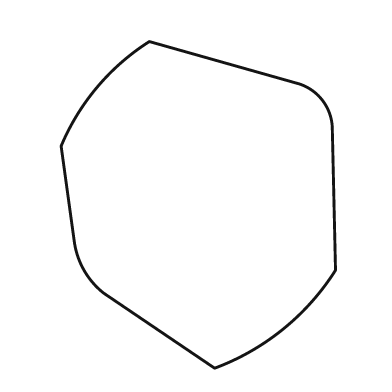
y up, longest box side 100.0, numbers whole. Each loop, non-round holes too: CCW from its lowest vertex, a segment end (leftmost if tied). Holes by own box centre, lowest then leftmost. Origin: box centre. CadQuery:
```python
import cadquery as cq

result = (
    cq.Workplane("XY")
    .moveTo(5.0, -50.0)
    .threePointArc((26.0, -38.0), (42.0, -20.0))
    .lineTo(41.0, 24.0)
    .threePointArc((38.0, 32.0), (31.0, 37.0))
    .lineTo(-15.0, 50.0)
    .threePointArc((-31.0, 36.0), (-42.0, 18.0))
    .lineTo(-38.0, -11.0)
    .threePointArc((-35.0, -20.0), (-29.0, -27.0))
    .close()
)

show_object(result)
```